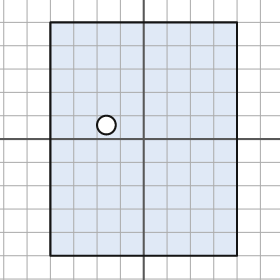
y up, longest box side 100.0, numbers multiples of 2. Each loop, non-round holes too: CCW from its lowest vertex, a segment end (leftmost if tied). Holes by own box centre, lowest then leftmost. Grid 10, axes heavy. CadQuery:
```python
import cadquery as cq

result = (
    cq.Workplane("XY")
    .moveTo(-40.0, -50.0)
    .lineTo(40.0, -50.0)
    .lineTo(40.0, 50.0)
    .lineTo(-40.0, 50.0)
    .close()
    .moveTo(-16.0, 6.0)
    .circle(4.0)
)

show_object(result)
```